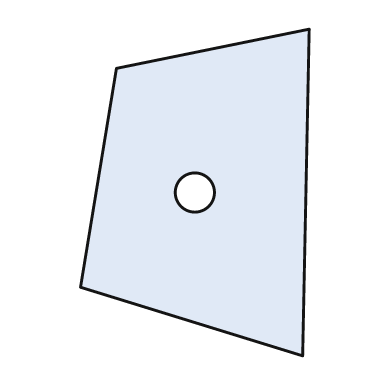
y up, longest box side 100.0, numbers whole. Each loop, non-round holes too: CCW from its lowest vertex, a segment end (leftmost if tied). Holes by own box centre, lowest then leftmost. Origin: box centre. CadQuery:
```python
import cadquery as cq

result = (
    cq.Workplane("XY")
    .moveTo(33.0, -50.0)
    .lineTo(35.0, 50.0)
    .lineTo(-24.0, 38.0)
    .lineTo(-35.0, -29.0)
    .close()
    .moveTo(0.0, 0.0)
    .circle(6.0)
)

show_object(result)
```